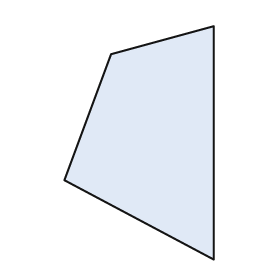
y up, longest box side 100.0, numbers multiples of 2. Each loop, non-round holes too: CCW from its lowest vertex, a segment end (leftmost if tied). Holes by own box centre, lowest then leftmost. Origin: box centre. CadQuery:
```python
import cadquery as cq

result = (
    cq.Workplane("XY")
    .moveTo(32.0, -50.0)
    .lineTo(32.0, 50.0)
    .lineTo(-12.0, 38.0)
    .lineTo(-32.0, -16.0)
    .close()
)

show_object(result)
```